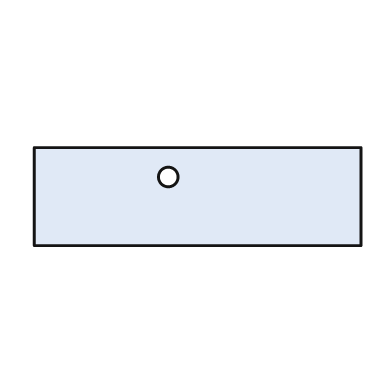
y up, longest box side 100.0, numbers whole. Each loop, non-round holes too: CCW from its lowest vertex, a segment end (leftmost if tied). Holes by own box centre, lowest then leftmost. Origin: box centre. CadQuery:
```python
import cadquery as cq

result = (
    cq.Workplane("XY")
    .moveTo(-50.0, -15.0)
    .lineTo(50.0, -15.0)
    .lineTo(50.0, 15.0)
    .lineTo(-50.0, 15.0)
    .close()
    .moveTo(-9.0, 6.0)
    .circle(3.0)
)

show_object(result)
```